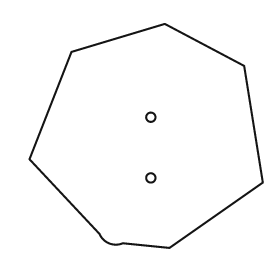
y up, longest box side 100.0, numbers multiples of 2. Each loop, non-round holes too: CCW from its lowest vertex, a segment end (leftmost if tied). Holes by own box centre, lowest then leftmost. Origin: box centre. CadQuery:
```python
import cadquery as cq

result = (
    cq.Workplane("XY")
    .moveTo(10.0, -48.0)
    .lineTo(50.0, -20.0)
    .lineTo(42.0, 30.0)
    .lineTo(8.0, 48.0)
    .lineTo(-32.0, 36.0)
    .lineTo(-50.0, -10.0)
    .lineTo(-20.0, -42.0)
    .threePointArc((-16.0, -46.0), (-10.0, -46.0))
    .close()
    .moveTo(2.0, -18.0)
    .circle(2.0)
    .moveTo(2.0, 8.0)
    .circle(2.0)
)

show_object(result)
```